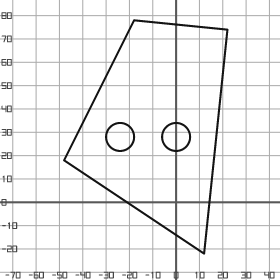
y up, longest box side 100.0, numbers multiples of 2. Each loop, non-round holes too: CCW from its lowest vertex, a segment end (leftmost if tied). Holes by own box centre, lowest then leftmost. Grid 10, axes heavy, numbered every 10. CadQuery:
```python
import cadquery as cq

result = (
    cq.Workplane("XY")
    .moveTo(12.0, -22.0)
    .lineTo(22.0, 74.0)
    .lineTo(-18.0, 78.0)
    .lineTo(-48.0, 18.0)
    .close()
    .moveTo(-24.0, 28.0)
    .circle(6.0)
    .moveTo(0.0, 28.0)
    .circle(6.0)
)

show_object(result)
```